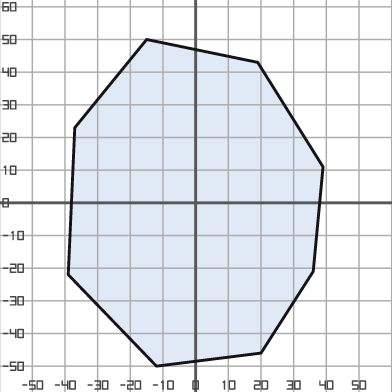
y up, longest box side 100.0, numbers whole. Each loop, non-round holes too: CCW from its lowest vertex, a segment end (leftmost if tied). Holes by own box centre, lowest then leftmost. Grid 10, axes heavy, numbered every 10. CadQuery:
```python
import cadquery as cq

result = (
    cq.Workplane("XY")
    .moveTo(-12.0, -50.0)
    .lineTo(20.0, -46.0)
    .lineTo(36.0, -21.0)
    .lineTo(39.0, 11.0)
    .lineTo(19.0, 43.0)
    .lineTo(-15.0, 50.0)
    .lineTo(-37.0, 23.0)
    .lineTo(-39.0, -22.0)
    .close()
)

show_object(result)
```